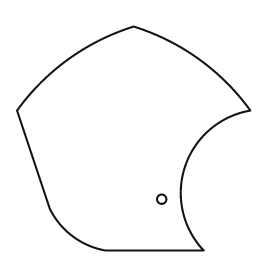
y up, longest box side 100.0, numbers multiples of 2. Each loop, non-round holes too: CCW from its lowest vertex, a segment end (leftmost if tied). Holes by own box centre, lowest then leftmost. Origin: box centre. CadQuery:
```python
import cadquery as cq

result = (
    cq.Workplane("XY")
    .moveTo(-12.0, -48.0)
    .lineTo(30.0, -48.0)
    .threePointArc((22.0, -12.0), (50.0, 12.0))
    .threePointArc((28.0, 34.0), (0.0, 48.0))
    .threePointArc((-28.0, 34.0), (-50.0, 12.0))
    .lineTo(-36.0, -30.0)
    .threePointArc((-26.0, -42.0), (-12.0, -48.0))
    .close()
    .moveTo(12.0, -26.0)
    .circle(2.0)
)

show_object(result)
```